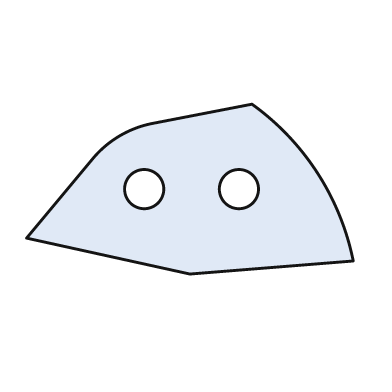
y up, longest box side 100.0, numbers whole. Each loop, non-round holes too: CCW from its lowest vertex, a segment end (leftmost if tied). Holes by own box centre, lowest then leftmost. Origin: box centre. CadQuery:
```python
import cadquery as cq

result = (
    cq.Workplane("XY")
    .moveTo(0.0, -26.0)
    .lineTo(50.0, -22.0)
    .threePointArc((39.0, 5.0), (19.0, 26.0))
    .lineTo(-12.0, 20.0)
    .threePointArc((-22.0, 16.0), (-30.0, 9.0))
    .lineTo(-50.0, -15.0)
    .close()
    .moveTo(-14.0, 0.0)
    .circle(6.0)
    .moveTo(15.0, 0.0)
    .circle(6.0)
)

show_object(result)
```